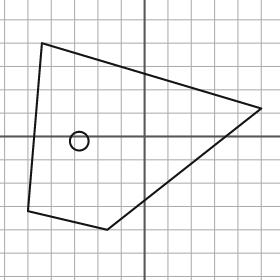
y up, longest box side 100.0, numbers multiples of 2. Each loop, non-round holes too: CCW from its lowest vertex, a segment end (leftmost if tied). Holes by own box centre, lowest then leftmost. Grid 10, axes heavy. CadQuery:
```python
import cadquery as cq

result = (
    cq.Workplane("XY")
    .moveTo(-16.0, -40.0)
    .lineTo(50.0, 12.0)
    .lineTo(-44.0, 40.0)
    .lineTo(-50.0, -32.0)
    .close()
    .moveTo(-28.0, -2.0)
    .circle(4.0)
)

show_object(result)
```